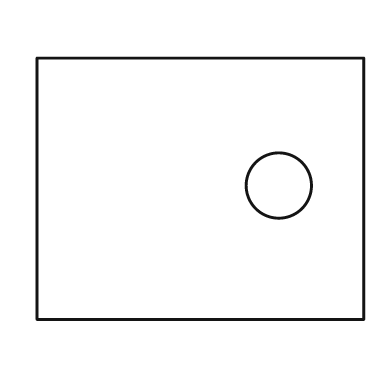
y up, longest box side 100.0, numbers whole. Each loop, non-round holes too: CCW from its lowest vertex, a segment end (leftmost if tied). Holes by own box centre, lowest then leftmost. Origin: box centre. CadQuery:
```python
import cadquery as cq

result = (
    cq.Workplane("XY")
    .moveTo(-50.0, -40.0)
    .lineTo(50.0, -40.0)
    .lineTo(50.0, 40.0)
    .lineTo(-50.0, 40.0)
    .close()
    .moveTo(24.0, 1.0)
    .circle(10.0)
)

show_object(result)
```